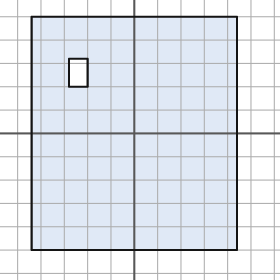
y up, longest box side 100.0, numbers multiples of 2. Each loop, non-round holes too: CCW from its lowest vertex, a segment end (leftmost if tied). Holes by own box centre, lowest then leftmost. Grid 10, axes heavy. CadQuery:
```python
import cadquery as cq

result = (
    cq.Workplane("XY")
    .moveTo(-44.0, -50.0)
    .lineTo(44.0, -50.0)
    .lineTo(44.0, 50.0)
    .lineTo(-44.0, 50.0)
    .close()
    .moveTo(-28.0, 20.0)
    .lineTo(-20.0, 20.0)
    .lineTo(-20.0, 32.0)
    .lineTo(-28.0, 32.0)
    .close()
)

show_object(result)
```